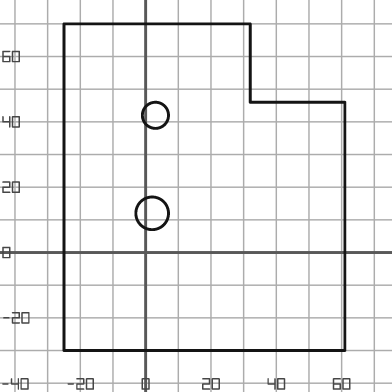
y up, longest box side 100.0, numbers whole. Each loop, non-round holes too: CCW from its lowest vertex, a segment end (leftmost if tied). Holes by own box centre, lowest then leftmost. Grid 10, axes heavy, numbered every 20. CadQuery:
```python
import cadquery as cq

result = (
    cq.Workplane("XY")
    .moveTo(-25.0, -30.0)
    .lineTo(61.0, -30.0)
    .lineTo(61.0, 46.0)
    .lineTo(32.0, 46.0)
    .lineTo(32.0, 70.0)
    .lineTo(-25.0, 70.0)
    .close()
    .moveTo(2.0, 12.0)
    .circle(5.0)
    .moveTo(3.0, 42.0)
    .circle(4.0)
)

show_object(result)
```